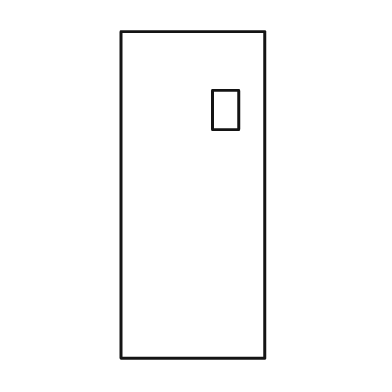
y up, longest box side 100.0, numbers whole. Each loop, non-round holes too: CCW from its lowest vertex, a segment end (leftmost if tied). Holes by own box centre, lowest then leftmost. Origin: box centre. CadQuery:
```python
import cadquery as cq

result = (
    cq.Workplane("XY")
    .moveTo(-22.0, -50.0)
    .lineTo(22.0, -50.0)
    .lineTo(22.0, 50.0)
    .lineTo(-22.0, 50.0)
    .close()
    .moveTo(6.0, 20.0)
    .lineTo(14.0, 20.0)
    .lineTo(14.0, 32.0)
    .lineTo(6.0, 32.0)
    .close()
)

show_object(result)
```